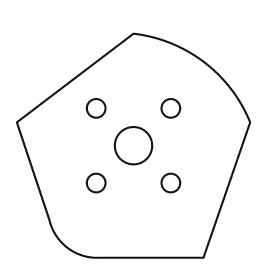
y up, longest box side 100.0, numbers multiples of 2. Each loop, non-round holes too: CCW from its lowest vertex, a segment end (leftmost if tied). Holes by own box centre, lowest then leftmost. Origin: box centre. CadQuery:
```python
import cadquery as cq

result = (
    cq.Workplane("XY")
    .moveTo(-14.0, -48.0)
    .lineTo(30.0, -48.0)
    .lineTo(50.0, 10.0)
    .threePointArc((30.0, 36.0), (0.0, 48.0))
    .lineTo(-50.0, 10.0)
    .lineTo(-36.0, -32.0)
    .threePointArc((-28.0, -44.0), (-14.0, -48.0))
    .close()
    .moveTo(-16.0, -16.0)
    .circle(4.0)
    .moveTo(16.0, -16.0)
    .circle(4.0)
    .moveTo(0.0, 0.0)
    .circle(8.0)
    .moveTo(-16.0, 16.0)
    .circle(4.0)
    .moveTo(16.0, 16.0)
    .circle(4.0)
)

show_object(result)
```